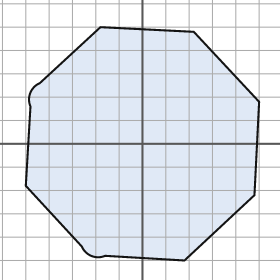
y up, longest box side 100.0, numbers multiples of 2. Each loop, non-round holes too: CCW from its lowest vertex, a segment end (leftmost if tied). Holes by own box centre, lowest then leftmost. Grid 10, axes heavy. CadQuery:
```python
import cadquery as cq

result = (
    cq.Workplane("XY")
    .moveTo(18.0, -50.0)
    .lineTo(48.0, -22.0)
    .lineTo(50.0, 18.0)
    .lineTo(22.0, 48.0)
    .lineTo(-18.0, 50.0)
    .lineTo(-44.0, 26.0)
    .threePointArc((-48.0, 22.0), (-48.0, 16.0))
    .lineTo(-50.0, -18.0)
    .lineTo(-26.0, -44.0)
    .threePointArc((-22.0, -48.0), (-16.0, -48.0))
    .close()
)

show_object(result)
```